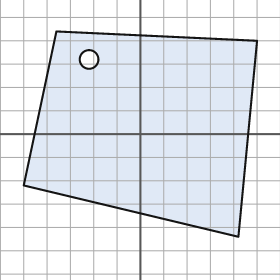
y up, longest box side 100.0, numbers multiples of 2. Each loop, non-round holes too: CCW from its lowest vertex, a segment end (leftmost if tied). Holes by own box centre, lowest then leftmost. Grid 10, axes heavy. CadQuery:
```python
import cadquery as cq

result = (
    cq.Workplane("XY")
    .moveTo(42.0, -44.0)
    .lineTo(50.0, 40.0)
    .lineTo(-36.0, 44.0)
    .lineTo(-50.0, -22.0)
    .close()
    .moveTo(-22.0, 32.0)
    .circle(4.0)
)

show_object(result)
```